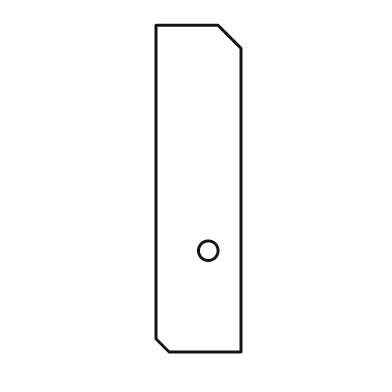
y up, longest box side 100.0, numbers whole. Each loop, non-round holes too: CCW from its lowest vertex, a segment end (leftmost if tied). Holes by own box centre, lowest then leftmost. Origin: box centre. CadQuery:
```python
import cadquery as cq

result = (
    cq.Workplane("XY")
    .moveTo(-9.0, -50.0)
    .lineTo(13.0, -50.0)
    .lineTo(13.0, 43.0)
    .lineTo(6.0, 50.0)
    .lineTo(-13.0, 50.0)
    .lineTo(-13.0, -46.0)
    .close()
    .moveTo(3.0, -19.0)
    .circle(3.0)
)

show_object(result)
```